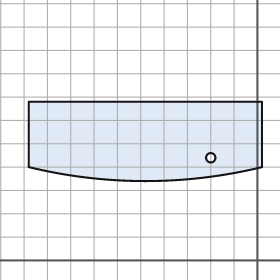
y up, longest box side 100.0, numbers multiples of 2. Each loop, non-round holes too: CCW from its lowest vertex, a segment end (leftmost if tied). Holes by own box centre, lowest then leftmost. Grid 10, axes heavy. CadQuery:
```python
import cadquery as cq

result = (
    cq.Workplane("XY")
    .moveTo(-98.0, 40.0)
    .threePointArc((-48.0, 34.0), (2.0, 40.0))
    .lineTo(2.0, 68.0)
    .lineTo(-98.0, 68.0)
    .close()
    .moveTo(-20.0, 44.0)
    .circle(2.0)
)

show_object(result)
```